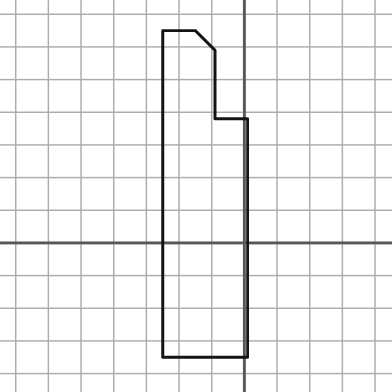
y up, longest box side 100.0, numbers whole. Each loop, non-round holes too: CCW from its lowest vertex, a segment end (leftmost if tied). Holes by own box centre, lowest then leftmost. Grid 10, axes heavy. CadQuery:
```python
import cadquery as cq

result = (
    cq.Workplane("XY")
    .moveTo(-25.0, -35.0)
    .lineTo(1.0, -35.0)
    .lineTo(1.0, 38.0)
    .lineTo(-9.0, 38.0)
    .lineTo(-9.0, 59.0)
    .lineTo(-15.0, 65.0)
    .lineTo(-25.0, 65.0)
    .close()
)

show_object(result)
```